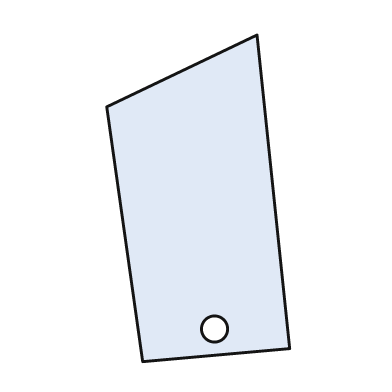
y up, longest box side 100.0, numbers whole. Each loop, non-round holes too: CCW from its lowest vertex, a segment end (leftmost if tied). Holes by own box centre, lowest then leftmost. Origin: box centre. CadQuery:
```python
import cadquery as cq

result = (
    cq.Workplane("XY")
    .moveTo(-17.0, -50.0)
    .lineTo(28.0, -46.0)
    .lineTo(18.0, 50.0)
    .lineTo(-28.0, 28.0)
    .close()
    .moveTo(5.0, -40.0)
    .circle(4.0)
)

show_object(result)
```